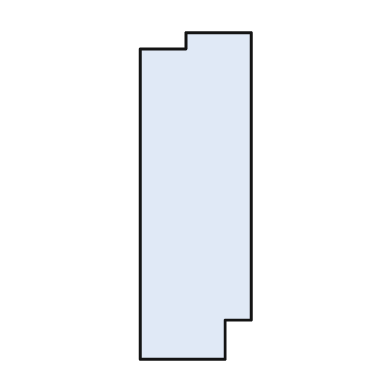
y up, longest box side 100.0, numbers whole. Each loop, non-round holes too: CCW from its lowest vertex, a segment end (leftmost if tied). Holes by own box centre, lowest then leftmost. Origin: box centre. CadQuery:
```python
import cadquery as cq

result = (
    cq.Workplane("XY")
    .moveTo(-17.0, -50.0)
    .lineTo(9.0, -50.0)
    .lineTo(9.0, -38.0)
    .lineTo(17.0, -38.0)
    .lineTo(17.0, 50.0)
    .lineTo(-3.0, 50.0)
    .lineTo(-3.0, 45.0)
    .lineTo(-17.0, 45.0)
    .close()
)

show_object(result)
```